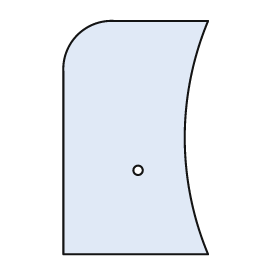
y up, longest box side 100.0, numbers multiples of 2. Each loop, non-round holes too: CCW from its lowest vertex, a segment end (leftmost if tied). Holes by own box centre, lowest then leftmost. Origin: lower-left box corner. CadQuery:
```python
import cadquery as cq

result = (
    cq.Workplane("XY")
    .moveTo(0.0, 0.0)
    .lineTo(62.0, 0.0)
    .threePointArc((52.0, 50.0), (62.0, 100.0))
    .lineTo(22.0, 100.0)
    .threePointArc((6.0, 94.0), (0.0, 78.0))
    .close()
    .moveTo(32.0, 36.0)
    .circle(2.0)
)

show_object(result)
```